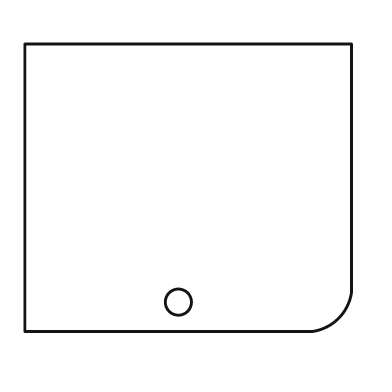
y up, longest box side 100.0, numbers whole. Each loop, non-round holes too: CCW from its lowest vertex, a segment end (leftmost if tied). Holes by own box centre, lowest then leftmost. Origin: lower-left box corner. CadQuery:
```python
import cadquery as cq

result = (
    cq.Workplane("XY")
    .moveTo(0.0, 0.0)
    .lineTo(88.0, 0.0)
    .threePointArc((96.0, 4.0), (100.0, 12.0))
    .lineTo(100.0, 88.0)
    .lineTo(0.0, 88.0)
    .close()
    .moveTo(47.0, 9.0)
    .circle(4.0)
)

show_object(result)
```